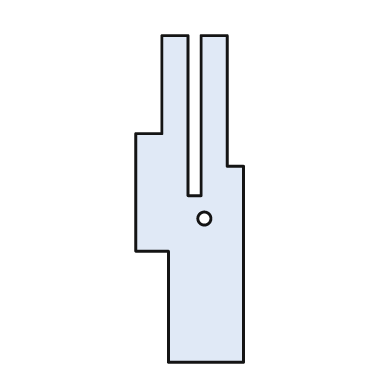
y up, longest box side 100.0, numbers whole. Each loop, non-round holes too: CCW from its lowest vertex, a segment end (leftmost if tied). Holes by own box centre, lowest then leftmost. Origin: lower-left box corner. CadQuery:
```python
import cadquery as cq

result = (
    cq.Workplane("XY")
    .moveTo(10.0, 0.0)
    .lineTo(33.0, 0.0)
    .lineTo(33.0, 60.0)
    .lineTo(28.0, 60.0)
    .lineTo(28.0, 100.0)
    .lineTo(20.0, 100.0)
    .lineTo(20.0, 51.0)
    .lineTo(16.0, 51.0)
    .lineTo(16.0, 100.0)
    .lineTo(8.0, 100.0)
    .lineTo(8.0, 70.0)
    .lineTo(0.0, 70.0)
    .lineTo(0.0, 34.0)
    .lineTo(10.0, 34.0)
    .close()
    .moveTo(21.0, 44.0)
    .circle(2.0)
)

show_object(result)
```